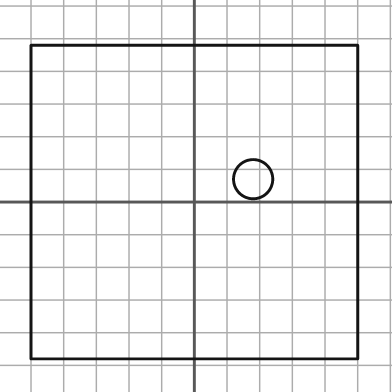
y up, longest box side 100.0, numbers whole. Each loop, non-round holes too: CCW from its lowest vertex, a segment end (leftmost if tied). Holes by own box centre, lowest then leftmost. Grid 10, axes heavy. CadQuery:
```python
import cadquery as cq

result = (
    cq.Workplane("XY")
    .moveTo(-50.0, -48.0)
    .lineTo(50.0, -48.0)
    .lineTo(50.0, 48.0)
    .lineTo(-50.0, 48.0)
    .close()
    .moveTo(18.0, 7.0)
    .circle(6.0)
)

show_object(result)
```